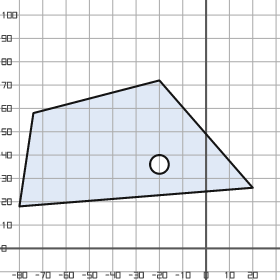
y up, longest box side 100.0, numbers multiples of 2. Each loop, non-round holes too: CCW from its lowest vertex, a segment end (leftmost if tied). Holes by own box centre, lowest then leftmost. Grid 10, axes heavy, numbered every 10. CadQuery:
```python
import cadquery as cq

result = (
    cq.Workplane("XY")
    .moveTo(-80.0, 18.0)
    .lineTo(20.0, 26.0)
    .lineTo(-20.0, 72.0)
    .lineTo(-74.0, 58.0)
    .close()
    .moveTo(-20.0, 36.0)
    .circle(4.0)
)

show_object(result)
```